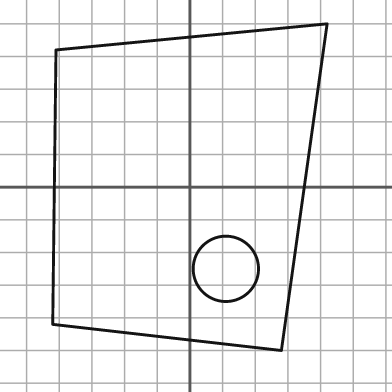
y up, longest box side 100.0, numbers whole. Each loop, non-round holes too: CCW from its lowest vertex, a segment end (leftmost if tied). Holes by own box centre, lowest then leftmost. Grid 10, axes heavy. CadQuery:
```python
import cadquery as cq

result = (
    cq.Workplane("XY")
    .moveTo(28.0, -50.0)
    .lineTo(42.0, 50.0)
    .lineTo(-41.0, 42.0)
    .lineTo(-42.0, -42.0)
    .close()
    .moveTo(11.0, -25.0)
    .circle(10.0)
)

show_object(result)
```